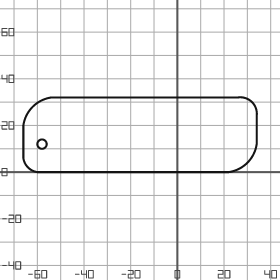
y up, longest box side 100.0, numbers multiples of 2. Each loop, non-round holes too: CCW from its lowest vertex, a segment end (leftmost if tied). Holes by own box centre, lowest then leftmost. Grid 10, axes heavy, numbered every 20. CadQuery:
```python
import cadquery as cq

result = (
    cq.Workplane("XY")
    .moveTo(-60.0, 0.0)
    .lineTo(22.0, 0.0)
    .threePointArc((30.0, 4.0), (34.0, 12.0))
    .lineTo(34.0, 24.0)
    .threePointArc((32.0, 30.0), (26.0, 32.0))
    .lineTo(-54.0, 32.0)
    .threePointArc((-62.0, 28.0), (-66.0, 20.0))
    .lineTo(-66.0, 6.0)
    .threePointArc((-64.0, 2.0), (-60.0, 0.0))
    .close()
    .moveTo(-58.0, 12.0)
    .circle(2.0)
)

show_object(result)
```